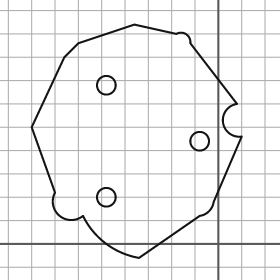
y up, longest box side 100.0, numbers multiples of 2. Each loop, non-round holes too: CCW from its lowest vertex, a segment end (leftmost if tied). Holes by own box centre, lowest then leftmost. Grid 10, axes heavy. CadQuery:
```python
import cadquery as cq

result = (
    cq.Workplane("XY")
    .moveTo(-34.0, -6.0)
    .lineTo(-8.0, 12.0)
    .threePointArc((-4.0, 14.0), (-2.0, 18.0))
    .lineTo(10.0, 46.0)
    .threePointArc((2.0, 52.0), (8.0, 60.0))
    .lineTo(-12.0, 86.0)
    .threePointArc((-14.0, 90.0), (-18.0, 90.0))
    .lineTo(-36.0, 94.0)
    .lineTo(-60.0, 86.0)
    .lineTo(-66.0, 80.0)
    .lineTo(-80.0, 50.0)
    .lineTo(-70.0, 22.0)
    .threePointArc((-68.0, 12.0), (-58.0, 12.0))
    .threePointArc((-48.0, 0.0), (-34.0, -6.0))
    .close()
    .moveTo(-48.0, 20.0)
    .circle(4.0)
    .moveTo(-8.0, 44.0)
    .circle(4.0)
    .moveTo(-48.0, 68.0)
    .circle(4.0)
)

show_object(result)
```